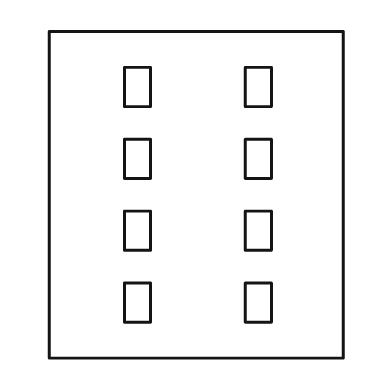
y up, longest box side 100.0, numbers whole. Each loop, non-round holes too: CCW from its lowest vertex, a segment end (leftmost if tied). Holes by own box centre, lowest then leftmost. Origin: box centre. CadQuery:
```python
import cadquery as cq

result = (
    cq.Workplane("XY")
    .moveTo(-45.0, -50.0)
    .lineTo(45.0, -50.0)
    .lineTo(45.0, 50.0)
    .lineTo(-45.0, 50.0)
    .close()
    .moveTo(-22.0, -39.0)
    .lineTo(-14.0, -39.0)
    .lineTo(-14.0, -27.0)
    .lineTo(-22.0, -27.0)
    .close()
    .moveTo(15.0, -39.0)
    .lineTo(23.0, -39.0)
    .lineTo(23.0, -27.0)
    .lineTo(15.0, -27.0)
    .close()
    .moveTo(-22.0, -17.0)
    .lineTo(-14.0, -17.0)
    .lineTo(-14.0, -5.0)
    .lineTo(-22.0, -5.0)
    .close()
    .moveTo(15.0, -17.0)
    .lineTo(23.0, -17.0)
    .lineTo(23.0, -5.0)
    .lineTo(15.0, -5.0)
    .close()
    .moveTo(-22.0, 5.0)
    .lineTo(-14.0, 5.0)
    .lineTo(-14.0, 17.0)
    .lineTo(-22.0, 17.0)
    .close()
    .moveTo(15.0, 5.0)
    .lineTo(23.0, 5.0)
    .lineTo(23.0, 17.0)
    .lineTo(15.0, 17.0)
    .close()
    .moveTo(-22.0, 27.0)
    .lineTo(-14.0, 27.0)
    .lineTo(-14.0, 39.0)
    .lineTo(-22.0, 39.0)
    .close()
    .moveTo(15.0, 27.0)
    .lineTo(23.0, 27.0)
    .lineTo(23.0, 39.0)
    .lineTo(15.0, 39.0)
    .close()
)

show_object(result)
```